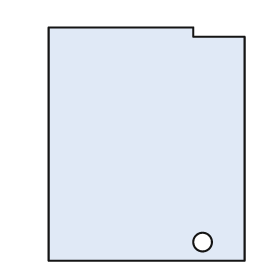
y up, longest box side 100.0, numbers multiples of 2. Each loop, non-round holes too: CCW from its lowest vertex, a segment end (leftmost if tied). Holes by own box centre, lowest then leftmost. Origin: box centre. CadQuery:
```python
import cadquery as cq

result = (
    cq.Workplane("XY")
    .moveTo(-42.0, -50.0)
    .lineTo(42.0, -50.0)
    .lineTo(42.0, 46.0)
    .lineTo(20.0, 46.0)
    .lineTo(20.0, 50.0)
    .lineTo(-42.0, 50.0)
    .close()
    .moveTo(24.0, -42.0)
    .circle(4.0)
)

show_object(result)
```